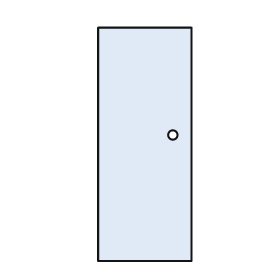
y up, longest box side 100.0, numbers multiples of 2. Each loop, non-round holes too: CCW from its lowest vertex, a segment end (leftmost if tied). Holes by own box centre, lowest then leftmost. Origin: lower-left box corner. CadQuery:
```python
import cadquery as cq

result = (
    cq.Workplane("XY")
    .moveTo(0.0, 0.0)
    .lineTo(40.0, 0.0)
    .lineTo(40.0, 100.0)
    .lineTo(0.0, 100.0)
    .close()
    .moveTo(32.0, 54.0)
    .circle(2.0)
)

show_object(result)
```